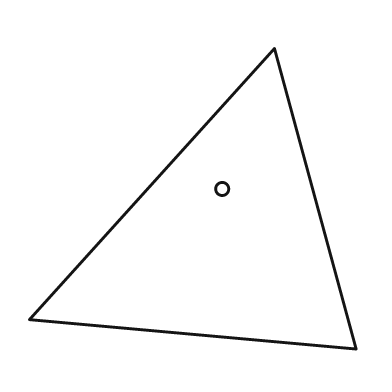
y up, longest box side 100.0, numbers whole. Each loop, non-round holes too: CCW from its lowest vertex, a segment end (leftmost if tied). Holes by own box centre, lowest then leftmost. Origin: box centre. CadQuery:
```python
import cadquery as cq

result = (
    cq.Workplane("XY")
    .moveTo(50.0, -46.0)
    .lineTo(25.0, 46.0)
    .lineTo(-50.0, -37.0)
    .close()
    .moveTo(9.0, 3.0)
    .circle(2.0)
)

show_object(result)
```